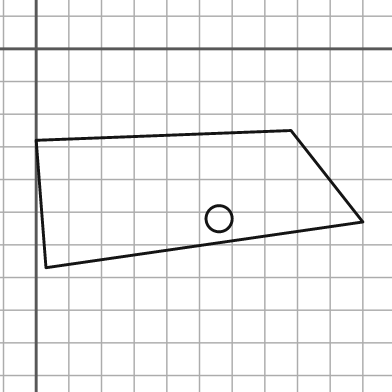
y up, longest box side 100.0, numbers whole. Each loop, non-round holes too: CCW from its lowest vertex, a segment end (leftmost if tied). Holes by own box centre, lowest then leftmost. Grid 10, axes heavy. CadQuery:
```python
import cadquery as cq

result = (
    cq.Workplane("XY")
    .moveTo(3.0, -67.0)
    .lineTo(100.0, -53.0)
    .lineTo(78.0, -25.0)
    .lineTo(0.0, -28.0)
    .close()
    .moveTo(56.0, -52.0)
    .circle(4.0)
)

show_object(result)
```